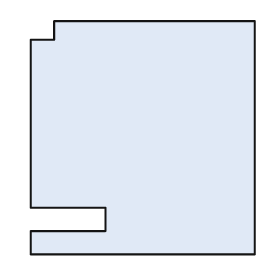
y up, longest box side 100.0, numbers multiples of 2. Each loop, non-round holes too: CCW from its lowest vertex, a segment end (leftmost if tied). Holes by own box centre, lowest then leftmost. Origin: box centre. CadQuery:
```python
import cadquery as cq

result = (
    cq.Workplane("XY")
    .moveTo(-48.0, -50.0)
    .lineTo(48.0, -50.0)
    .lineTo(48.0, 50.0)
    .lineTo(-38.0, 50.0)
    .lineTo(-38.0, 42.0)
    .lineTo(-48.0, 42.0)
    .lineTo(-48.0, -30.0)
    .lineTo(-16.0, -30.0)
    .lineTo(-16.0, -40.0)
    .lineTo(-48.0, -40.0)
    .close()
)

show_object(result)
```